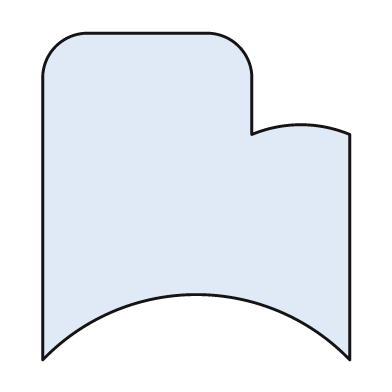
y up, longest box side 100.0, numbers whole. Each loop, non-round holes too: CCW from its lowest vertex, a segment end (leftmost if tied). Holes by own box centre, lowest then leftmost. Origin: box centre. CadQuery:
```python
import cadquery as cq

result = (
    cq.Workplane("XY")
    .moveTo(-47.0, -50.0)
    .threePointArc((0.0, -30.0), (47.0, -50.0))
    .lineTo(47.0, 19.0)
    .threePointArc((32.0, 22.0), (17.0, 19.0))
    .lineTo(17.0, 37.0)
    .threePointArc((13.0, 46.0), (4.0, 50.0))
    .lineTo(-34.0, 50.0)
    .threePointArc((-43.0, 46.0), (-47.0, 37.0))
    .close()
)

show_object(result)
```